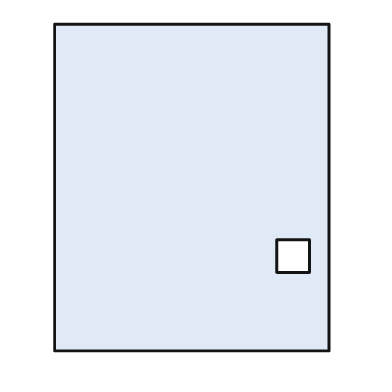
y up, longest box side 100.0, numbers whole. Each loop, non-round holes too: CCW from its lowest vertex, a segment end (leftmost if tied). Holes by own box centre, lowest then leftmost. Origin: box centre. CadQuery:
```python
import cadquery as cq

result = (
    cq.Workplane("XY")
    .moveTo(-42.0, -50.0)
    .lineTo(42.0, -50.0)
    .lineTo(42.0, 50.0)
    .lineTo(-42.0, 50.0)
    .close()
    .moveTo(26.0, -26.0)
    .lineTo(36.0, -26.0)
    .lineTo(36.0, -16.0)
    .lineTo(26.0, -16.0)
    .close()
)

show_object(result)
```